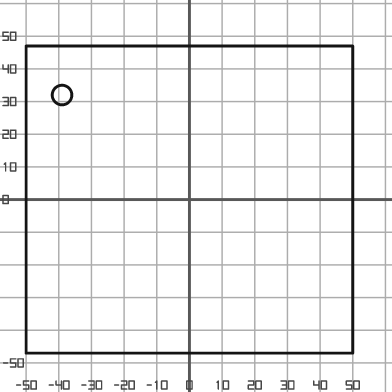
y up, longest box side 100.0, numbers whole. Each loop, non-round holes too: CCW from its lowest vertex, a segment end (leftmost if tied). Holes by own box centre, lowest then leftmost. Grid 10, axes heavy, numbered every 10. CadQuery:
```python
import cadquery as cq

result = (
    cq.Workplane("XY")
    .moveTo(-50.0, -47.0)
    .lineTo(50.0, -47.0)
    .lineTo(50.0, 47.0)
    .lineTo(-50.0, 47.0)
    .close()
    .moveTo(-39.0, 32.0)
    .circle(3.0)
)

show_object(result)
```